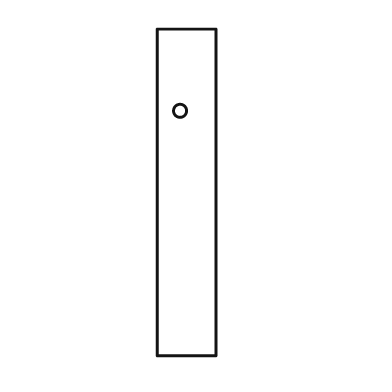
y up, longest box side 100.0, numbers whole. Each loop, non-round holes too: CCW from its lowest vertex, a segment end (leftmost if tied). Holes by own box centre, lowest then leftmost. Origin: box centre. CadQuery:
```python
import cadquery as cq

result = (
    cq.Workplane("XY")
    .moveTo(-9.0, -50.0)
    .lineTo(9.0, -50.0)
    .lineTo(9.0, 50.0)
    .lineTo(-9.0, 50.0)
    .close()
    .moveTo(-2.0, 25.0)
    .circle(2.0)
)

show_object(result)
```